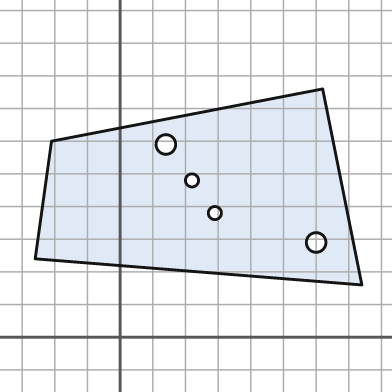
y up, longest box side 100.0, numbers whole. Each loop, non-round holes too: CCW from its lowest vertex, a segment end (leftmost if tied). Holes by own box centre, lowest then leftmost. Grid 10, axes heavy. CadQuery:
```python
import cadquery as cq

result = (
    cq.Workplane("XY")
    .moveTo(74.0, 16.0)
    .lineTo(62.0, 76.0)
    .lineTo(-21.0, 60.0)
    .lineTo(-26.0, 24.0)
    .close()
    .moveTo(60.0, 29.0)
    .circle(3.0)
    .moveTo(29.0, 38.0)
    .circle(2.0)
    .moveTo(22.0, 48.0)
    .circle(2.0)
    .moveTo(14.0, 59.0)
    .circle(3.0)
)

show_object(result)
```